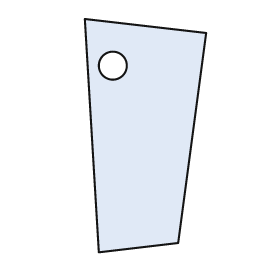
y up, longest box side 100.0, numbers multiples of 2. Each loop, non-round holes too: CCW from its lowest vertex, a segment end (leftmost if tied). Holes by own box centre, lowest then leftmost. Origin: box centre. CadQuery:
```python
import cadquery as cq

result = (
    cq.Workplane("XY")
    .moveTo(-20.0, -50.0)
    .lineTo(14.0, -46.0)
    .lineTo(26.0, 44.0)
    .lineTo(-26.0, 50.0)
    .close()
    .moveTo(-14.0, 30.0)
    .circle(6.0)
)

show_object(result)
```